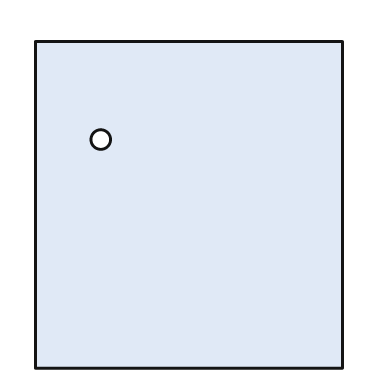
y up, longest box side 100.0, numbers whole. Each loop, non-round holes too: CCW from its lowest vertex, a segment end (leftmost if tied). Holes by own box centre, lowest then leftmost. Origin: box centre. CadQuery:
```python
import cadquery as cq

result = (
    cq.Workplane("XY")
    .moveTo(-47.0, -50.0)
    .lineTo(47.0, -50.0)
    .lineTo(47.0, 50.0)
    .lineTo(-47.0, 50.0)
    .close()
    .moveTo(-27.0, 20.0)
    .circle(3.0)
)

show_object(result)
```